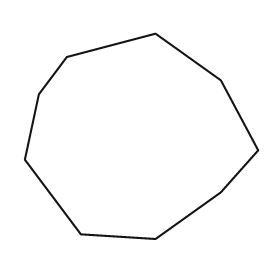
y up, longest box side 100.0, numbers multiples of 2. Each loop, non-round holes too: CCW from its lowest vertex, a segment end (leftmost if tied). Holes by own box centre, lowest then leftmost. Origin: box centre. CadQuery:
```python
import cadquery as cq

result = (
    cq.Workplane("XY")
    .moveTo(6.0, -44.0)
    .lineTo(34.0, -24.0)
    .lineTo(50.0, -6.0)
    .lineTo(34.0, 24.0)
    .lineTo(6.0, 44.0)
    .lineTo(-32.0, 34.0)
    .lineTo(-44.0, 18.0)
    .lineTo(-50.0, -10.0)
    .lineTo(-26.0, -42.0)
    .close()
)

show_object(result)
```